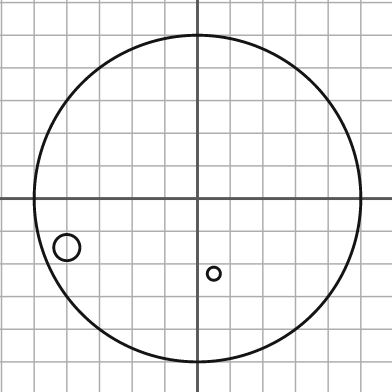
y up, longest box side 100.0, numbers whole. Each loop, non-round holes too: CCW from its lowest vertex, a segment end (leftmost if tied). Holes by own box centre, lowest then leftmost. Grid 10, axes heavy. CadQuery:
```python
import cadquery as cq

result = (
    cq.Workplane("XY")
    .moveTo(0.0, 0.0)
    .circle(50.0)
    .moveTo(5.0, -23.0)
    .circle(2.0)
    .moveTo(-40.0, -15.0)
    .circle(4.0)
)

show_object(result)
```